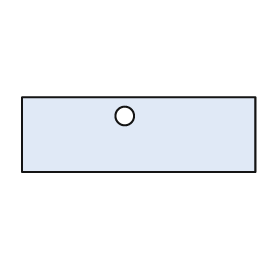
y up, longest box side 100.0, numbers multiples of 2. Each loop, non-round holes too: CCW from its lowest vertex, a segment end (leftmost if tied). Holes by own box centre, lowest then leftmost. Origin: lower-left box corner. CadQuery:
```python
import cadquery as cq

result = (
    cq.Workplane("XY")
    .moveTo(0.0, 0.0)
    .lineTo(100.0, 0.0)
    .lineTo(100.0, 32.0)
    .lineTo(0.0, 32.0)
    .close()
    .moveTo(44.0, 24.0)
    .circle(4.0)
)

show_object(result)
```